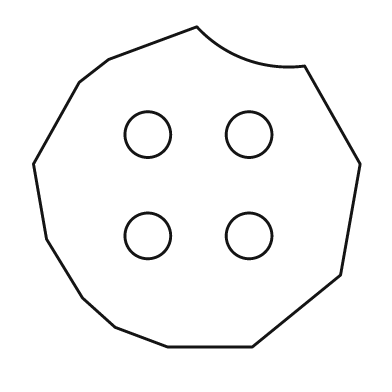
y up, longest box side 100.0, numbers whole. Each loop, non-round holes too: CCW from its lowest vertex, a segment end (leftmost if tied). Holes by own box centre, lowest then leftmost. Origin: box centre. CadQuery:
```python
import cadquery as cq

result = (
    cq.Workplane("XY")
    .moveTo(-9.0, -49.0)
    .lineTo(17.0, -49.0)
    .lineTo(44.0, -27.0)
    .lineTo(50.0, 7.0)
    .lineTo(33.0, 37.0)
    .threePointArc((15.0, 39.0), (0.0, 49.0))
    .lineTo(-27.0, 39.0)
    .lineTo(-36.0, 32.0)
    .lineTo(-50.0, 7.0)
    .lineTo(-46.0, -16.0)
    .lineTo(-35.0, -34.0)
    .lineTo(-25.0, -43.0)
    .close()
    .moveTo(-15.0, -15.0)
    .circle(7.0)
    .moveTo(16.0, -15.0)
    .circle(7.0)
    .moveTo(-15.0, 16.0)
    .circle(7.0)
    .moveTo(16.0, 16.0)
    .circle(7.0)
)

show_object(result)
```